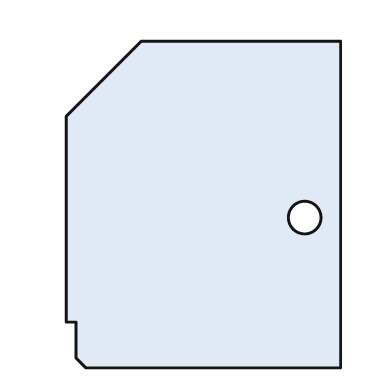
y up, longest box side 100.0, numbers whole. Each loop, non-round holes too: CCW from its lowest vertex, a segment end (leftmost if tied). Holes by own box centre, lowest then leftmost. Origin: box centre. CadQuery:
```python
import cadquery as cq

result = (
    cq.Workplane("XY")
    .moveTo(-36.0, -50.0)
    .lineTo(42.0, -50.0)
    .lineTo(42.0, 50.0)
    .lineTo(-19.0, 50.0)
    .lineTo(-42.0, 27.0)
    .lineTo(-42.0, -36.0)
    .lineTo(-39.0, -36.0)
    .lineTo(-39.0, -47.0)
    .close()
    .moveTo(31.0, -4.0)
    .circle(5.0)
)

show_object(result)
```